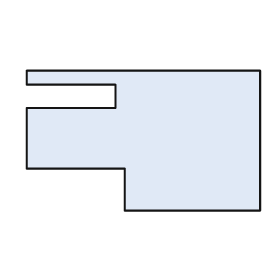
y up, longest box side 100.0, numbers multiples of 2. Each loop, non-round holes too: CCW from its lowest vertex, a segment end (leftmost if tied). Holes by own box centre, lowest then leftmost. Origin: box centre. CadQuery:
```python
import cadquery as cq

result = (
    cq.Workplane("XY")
    .moveTo(-8.0, -30.0)
    .lineTo(50.0, -30.0)
    .lineTo(50.0, 30.0)
    .lineTo(-50.0, 30.0)
    .lineTo(-50.0, 24.0)
    .lineTo(-12.0, 24.0)
    .lineTo(-12.0, 14.0)
    .lineTo(-50.0, 14.0)
    .lineTo(-50.0, -12.0)
    .lineTo(-8.0, -12.0)
    .close()
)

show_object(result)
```